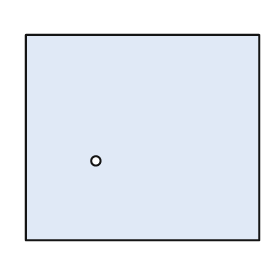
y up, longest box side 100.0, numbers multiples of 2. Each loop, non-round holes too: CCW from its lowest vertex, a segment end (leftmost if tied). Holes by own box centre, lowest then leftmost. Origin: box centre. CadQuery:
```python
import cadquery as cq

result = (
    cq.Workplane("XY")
    .moveTo(-50.0, -44.0)
    .lineTo(50.0, -44.0)
    .lineTo(50.0, 44.0)
    .lineTo(-50.0, 44.0)
    .close()
    .moveTo(-20.0, -10.0)
    .circle(2.0)
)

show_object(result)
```